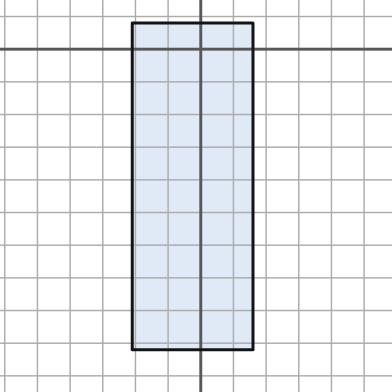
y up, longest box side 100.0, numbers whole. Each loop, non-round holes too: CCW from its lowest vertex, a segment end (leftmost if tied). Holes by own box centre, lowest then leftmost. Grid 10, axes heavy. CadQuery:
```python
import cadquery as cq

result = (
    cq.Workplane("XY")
    .moveTo(-21.0, -92.0)
    .lineTo(16.0, -92.0)
    .lineTo(16.0, 8.0)
    .lineTo(-21.0, 8.0)
    .close()
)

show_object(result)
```